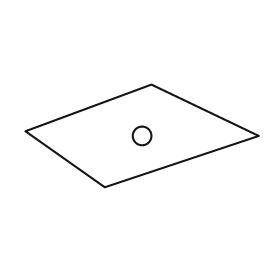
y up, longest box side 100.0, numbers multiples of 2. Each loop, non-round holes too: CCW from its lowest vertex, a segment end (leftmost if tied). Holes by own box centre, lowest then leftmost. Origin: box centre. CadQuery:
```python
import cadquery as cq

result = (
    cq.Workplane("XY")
    .moveTo(-16.0, -22.0)
    .lineTo(50.0, 0.0)
    .lineTo(4.0, 22.0)
    .lineTo(-50.0, 2.0)
    .close()
    .moveTo(0.0, 0.0)
    .circle(4.0)
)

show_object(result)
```